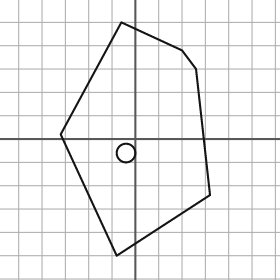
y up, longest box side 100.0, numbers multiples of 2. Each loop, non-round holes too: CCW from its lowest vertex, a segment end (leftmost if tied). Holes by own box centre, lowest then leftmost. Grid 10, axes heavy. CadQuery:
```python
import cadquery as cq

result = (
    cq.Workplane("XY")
    .moveTo(-8.0, -50.0)
    .lineTo(32.0, -24.0)
    .lineTo(26.0, 30.0)
    .lineTo(20.0, 38.0)
    .lineTo(-6.0, 50.0)
    .lineTo(-32.0, 2.0)
    .close()
    .moveTo(-4.0, -6.0)
    .circle(4.0)
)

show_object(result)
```